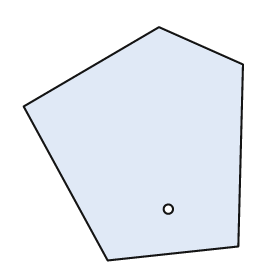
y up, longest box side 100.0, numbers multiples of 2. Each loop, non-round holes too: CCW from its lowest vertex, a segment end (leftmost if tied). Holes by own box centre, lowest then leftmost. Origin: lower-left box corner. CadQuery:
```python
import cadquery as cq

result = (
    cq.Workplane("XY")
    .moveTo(36.0, 0.0)
    .lineTo(92.0, 6.0)
    .lineTo(94.0, 84.0)
    .lineTo(58.0, 100.0)
    .lineTo(0.0, 66.0)
    .close()
    .moveTo(62.0, 22.0)
    .circle(2.0)
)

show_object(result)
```